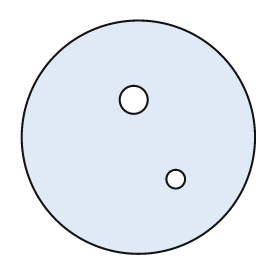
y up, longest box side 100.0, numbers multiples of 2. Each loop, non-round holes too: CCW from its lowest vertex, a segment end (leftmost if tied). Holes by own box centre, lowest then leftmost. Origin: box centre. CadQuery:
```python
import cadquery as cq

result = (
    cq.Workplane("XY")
    .moveTo(0.0, 0.0)
    .circle(50.0)
    .moveTo(16.0, -18.0)
    .circle(4.0)
    .moveTo(-2.0, 16.0)
    .circle(6.0)
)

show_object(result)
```